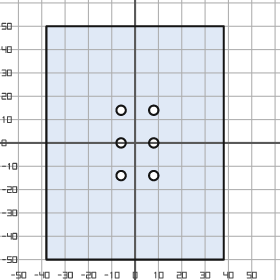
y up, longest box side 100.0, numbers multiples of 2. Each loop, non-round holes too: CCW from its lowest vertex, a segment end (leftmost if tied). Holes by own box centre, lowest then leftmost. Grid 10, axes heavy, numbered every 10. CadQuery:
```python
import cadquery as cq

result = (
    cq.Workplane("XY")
    .moveTo(-38.0, -50.0)
    .lineTo(38.0, -50.0)
    .lineTo(38.0, 50.0)
    .lineTo(-38.0, 50.0)
    .close()
    .moveTo(-6.0, -14.0)
    .circle(2.0)
    .moveTo(8.0, -14.0)
    .circle(2.0)
    .moveTo(-6.0, 0.0)
    .circle(2.0)
    .moveTo(8.0, 0.0)
    .circle(2.0)
    .moveTo(-6.0, 14.0)
    .circle(2.0)
    .moveTo(8.0, 14.0)
    .circle(2.0)
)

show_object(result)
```